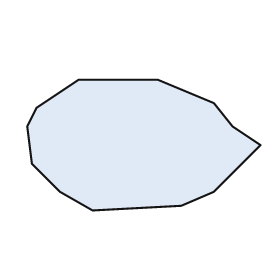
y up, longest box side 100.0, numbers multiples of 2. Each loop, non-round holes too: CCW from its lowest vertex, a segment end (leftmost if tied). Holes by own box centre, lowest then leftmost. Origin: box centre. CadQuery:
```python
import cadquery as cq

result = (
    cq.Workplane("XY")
    .moveTo(-22.0, -28.0)
    .lineTo(16.0, -26.0)
    .lineTo(30.0, -20.0)
    .lineTo(50.0, 0.0)
    .lineTo(38.0, 8.0)
    .lineTo(30.0, 18.0)
    .lineTo(6.0, 28.0)
    .lineTo(-28.0, 28.0)
    .lineTo(-46.0, 16.0)
    .lineTo(-50.0, 8.0)
    .lineTo(-48.0, -8.0)
    .lineTo(-36.0, -20.0)
    .close()
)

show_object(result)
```